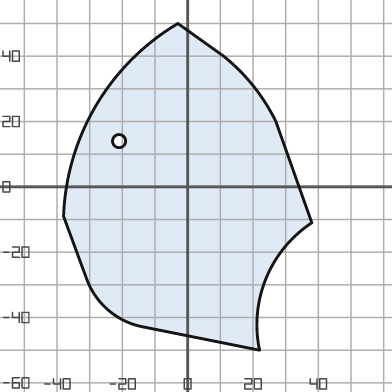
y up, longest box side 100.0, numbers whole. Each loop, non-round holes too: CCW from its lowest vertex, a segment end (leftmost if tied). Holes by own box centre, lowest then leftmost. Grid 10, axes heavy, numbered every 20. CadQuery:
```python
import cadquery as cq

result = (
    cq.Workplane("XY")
    .moveTo(22.0, -50.0)
    .threePointArc((24.0, -28.0), (38.0, -11.0))
    .lineTo(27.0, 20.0)
    .threePointArc((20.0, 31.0), (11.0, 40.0))
    .lineTo(-3.0, 50.0)
    .threePointArc((-28.0, 25.0), (-38.0, -9.0))
    .lineTo(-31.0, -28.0)
    .threePointArc((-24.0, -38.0), (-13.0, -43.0))
    .close()
    .moveTo(-21.0, 14.0)
    .circle(2.0)
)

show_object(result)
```